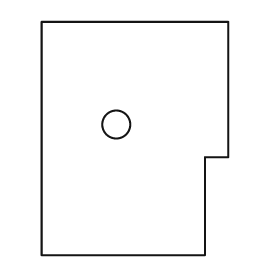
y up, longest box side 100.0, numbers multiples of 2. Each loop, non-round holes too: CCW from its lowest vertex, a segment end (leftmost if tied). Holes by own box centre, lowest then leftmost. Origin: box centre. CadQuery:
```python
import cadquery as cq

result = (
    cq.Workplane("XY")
    .moveTo(-40.0, -50.0)
    .lineTo(30.0, -50.0)
    .lineTo(30.0, -8.0)
    .lineTo(40.0, -8.0)
    .lineTo(40.0, 50.0)
    .lineTo(-40.0, 50.0)
    .close()
    .moveTo(-8.0, 6.0)
    .circle(6.0)
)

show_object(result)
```